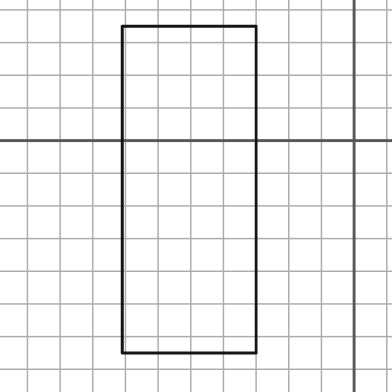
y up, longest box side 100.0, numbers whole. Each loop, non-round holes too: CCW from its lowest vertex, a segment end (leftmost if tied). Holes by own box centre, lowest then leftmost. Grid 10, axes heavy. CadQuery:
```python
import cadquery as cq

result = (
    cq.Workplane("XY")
    .moveTo(-71.0, -65.0)
    .lineTo(-30.0, -65.0)
    .lineTo(-30.0, 35.0)
    .lineTo(-71.0, 35.0)
    .close()
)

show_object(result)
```